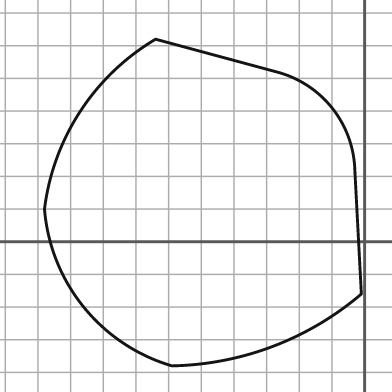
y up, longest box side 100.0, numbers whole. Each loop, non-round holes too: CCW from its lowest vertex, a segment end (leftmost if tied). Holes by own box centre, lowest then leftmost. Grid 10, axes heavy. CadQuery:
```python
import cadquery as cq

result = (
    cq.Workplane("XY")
    .moveTo(-59.0, -38.0)
    .threePointArc((-28.0, -32.0), (-1.0, -16.0))
    .lineTo(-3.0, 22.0)
    .threePointArc((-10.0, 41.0), (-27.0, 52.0))
    .lineTo(-64.0, 62.0)
    .threePointArc((-87.0, 40.0), (-98.0, 10.0))
    .threePointArc((-86.0, -20.0), (-59.0, -38.0))
    .close()
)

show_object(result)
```